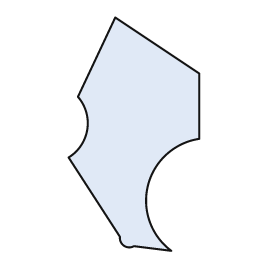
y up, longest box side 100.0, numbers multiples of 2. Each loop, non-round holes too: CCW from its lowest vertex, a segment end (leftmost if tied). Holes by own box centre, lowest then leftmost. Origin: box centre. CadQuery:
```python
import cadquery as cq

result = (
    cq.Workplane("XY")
    .moveTo(16.0, -50.0)
    .threePointArc((6.0, -22.0), (28.0, -2.0))
    .lineTo(28.0, 26.0)
    .lineTo(-8.0, 50.0)
    .lineTo(-24.0, 16.0)
    .threePointArc((-20.0, 2.0), (-28.0, -10.0))
    .lineTo(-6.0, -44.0)
    .threePointArc((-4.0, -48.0), (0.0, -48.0))
    .close()
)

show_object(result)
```